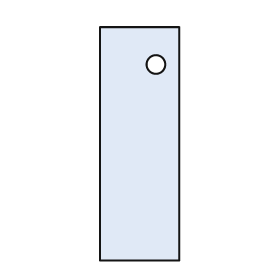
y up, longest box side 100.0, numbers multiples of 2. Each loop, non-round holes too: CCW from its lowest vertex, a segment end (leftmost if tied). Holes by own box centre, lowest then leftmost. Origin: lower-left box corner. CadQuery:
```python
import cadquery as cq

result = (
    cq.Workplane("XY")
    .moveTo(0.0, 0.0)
    .lineTo(34.0, 0.0)
    .lineTo(34.0, 100.0)
    .lineTo(0.0, 100.0)
    .close()
    .moveTo(24.0, 84.0)
    .circle(4.0)
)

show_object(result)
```